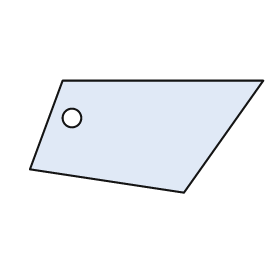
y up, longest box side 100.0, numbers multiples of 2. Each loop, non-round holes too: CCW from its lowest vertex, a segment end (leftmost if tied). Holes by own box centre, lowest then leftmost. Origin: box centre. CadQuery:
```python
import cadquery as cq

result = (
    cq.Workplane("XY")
    .moveTo(16.0, -24.0)
    .lineTo(50.0, 24.0)
    .lineTo(-36.0, 24.0)
    .lineTo(-50.0, -14.0)
    .close()
    .moveTo(-32.0, 8.0)
    .circle(4.0)
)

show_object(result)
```